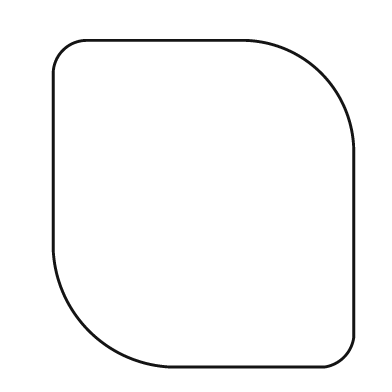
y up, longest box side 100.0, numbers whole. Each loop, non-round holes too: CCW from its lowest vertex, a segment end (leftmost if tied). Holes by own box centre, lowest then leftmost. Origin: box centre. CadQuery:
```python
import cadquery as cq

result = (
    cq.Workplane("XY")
    .moveTo(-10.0, -50.0)
    .lineTo(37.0, -50.0)
    .threePointArc((43.0, -47.0), (46.0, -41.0))
    .lineTo(46.0, 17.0)
    .threePointArc((36.0, 40.0), (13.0, 50.0))
    .lineTo(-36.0, 50.0)
    .threePointArc((-43.0, 47.0), (-46.0, 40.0))
    .lineTo(-46.0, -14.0)
    .threePointArc((-35.0, -39.0), (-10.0, -50.0))
    .close()
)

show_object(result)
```